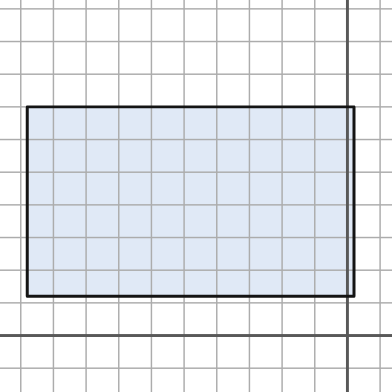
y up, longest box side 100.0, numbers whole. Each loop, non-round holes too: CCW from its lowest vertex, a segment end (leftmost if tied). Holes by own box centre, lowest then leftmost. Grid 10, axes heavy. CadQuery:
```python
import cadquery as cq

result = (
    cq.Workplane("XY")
    .moveTo(-98.0, 12.0)
    .lineTo(2.0, 12.0)
    .lineTo(2.0, 70.0)
    .lineTo(-98.0, 70.0)
    .close()
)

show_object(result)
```